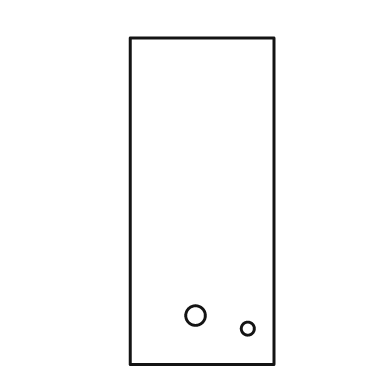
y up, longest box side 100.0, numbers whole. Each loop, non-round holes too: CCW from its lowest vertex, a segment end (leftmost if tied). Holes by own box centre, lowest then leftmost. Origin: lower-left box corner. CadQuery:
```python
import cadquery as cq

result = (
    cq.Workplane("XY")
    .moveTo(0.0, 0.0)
    .lineTo(44.0, 0.0)
    .lineTo(44.0, 100.0)
    .lineTo(0.0, 100.0)
    .close()
    .moveTo(36.0, 11.0)
    .circle(2.0)
    .moveTo(20.0, 15.0)
    .circle(3.0)
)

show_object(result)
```